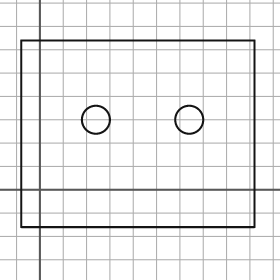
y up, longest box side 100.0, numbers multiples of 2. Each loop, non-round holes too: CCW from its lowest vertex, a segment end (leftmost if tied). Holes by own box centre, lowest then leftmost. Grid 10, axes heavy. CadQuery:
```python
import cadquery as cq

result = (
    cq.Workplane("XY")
    .moveTo(-8.0, -16.0)
    .lineTo(92.0, -16.0)
    .lineTo(92.0, 64.0)
    .lineTo(-8.0, 64.0)
    .close()
    .moveTo(24.0, 30.0)
    .circle(6.0)
    .moveTo(64.0, 30.0)
    .circle(6.0)
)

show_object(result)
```